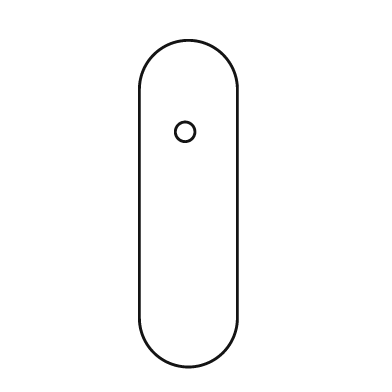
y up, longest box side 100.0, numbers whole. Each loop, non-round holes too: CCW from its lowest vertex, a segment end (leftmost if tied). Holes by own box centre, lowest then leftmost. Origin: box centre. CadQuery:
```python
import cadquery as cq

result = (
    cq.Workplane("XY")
    .moveTo(-15.0, -35.0)
    .threePointArc((0.0, -50.0), (15.0, -35.0))
    .lineTo(15.0, 35.0)
    .threePointArc((0.0, 50.0), (-15.0, 35.0))
    .close()
    .moveTo(-1.0, 22.0)
    .circle(3.0)
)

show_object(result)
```